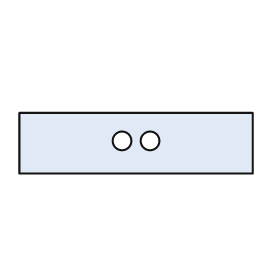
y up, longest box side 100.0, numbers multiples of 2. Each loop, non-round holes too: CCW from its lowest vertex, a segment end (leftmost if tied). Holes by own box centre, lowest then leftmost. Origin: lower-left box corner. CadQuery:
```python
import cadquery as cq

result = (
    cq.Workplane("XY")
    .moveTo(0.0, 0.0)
    .lineTo(100.0, 0.0)
    .lineTo(100.0, 26.0)
    .lineTo(0.0, 26.0)
    .close()
    .moveTo(44.0, 14.0)
    .circle(4.0)
    .moveTo(56.0, 14.0)
    .circle(4.0)
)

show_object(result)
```